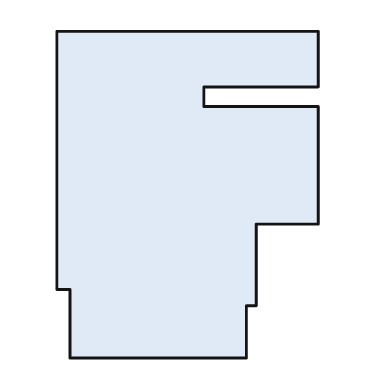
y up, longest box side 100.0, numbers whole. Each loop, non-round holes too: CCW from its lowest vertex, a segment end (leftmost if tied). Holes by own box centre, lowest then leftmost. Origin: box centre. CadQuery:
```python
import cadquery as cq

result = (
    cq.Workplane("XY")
    .moveTo(-36.0, -50.0)
    .lineTo(18.0, -50.0)
    .lineTo(18.0, -34.0)
    .lineTo(21.0, -34.0)
    .lineTo(21.0, -9.0)
    .lineTo(40.0, -9.0)
    .lineTo(40.0, 27.0)
    .lineTo(5.0, 27.0)
    .lineTo(5.0, 33.0)
    .lineTo(40.0, 33.0)
    .lineTo(40.0, 50.0)
    .lineTo(-40.0, 50.0)
    .lineTo(-40.0, -29.0)
    .lineTo(-36.0, -29.0)
    .close()
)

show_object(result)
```